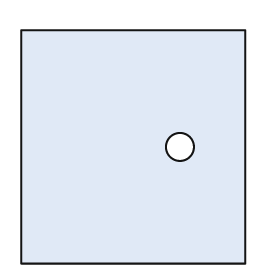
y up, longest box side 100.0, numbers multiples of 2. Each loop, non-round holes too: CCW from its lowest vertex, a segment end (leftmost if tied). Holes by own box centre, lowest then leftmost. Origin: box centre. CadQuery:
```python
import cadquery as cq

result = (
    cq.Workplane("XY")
    .moveTo(-48.0, -50.0)
    .lineTo(48.0, -50.0)
    .lineTo(48.0, 50.0)
    .lineTo(-48.0, 50.0)
    .close()
    .moveTo(20.0, 0.0)
    .circle(6.0)
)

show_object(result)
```